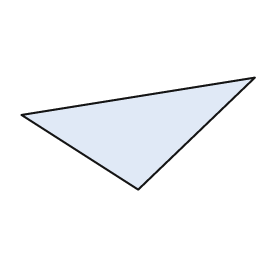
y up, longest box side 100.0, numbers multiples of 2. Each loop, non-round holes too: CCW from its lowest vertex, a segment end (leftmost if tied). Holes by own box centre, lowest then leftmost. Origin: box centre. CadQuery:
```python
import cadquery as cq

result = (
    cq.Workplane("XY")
    .moveTo(0.0, -24.0)
    .lineTo(50.0, 24.0)
    .lineTo(-50.0, 8.0)
    .close()
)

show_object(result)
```